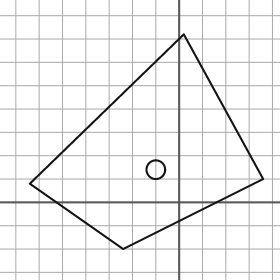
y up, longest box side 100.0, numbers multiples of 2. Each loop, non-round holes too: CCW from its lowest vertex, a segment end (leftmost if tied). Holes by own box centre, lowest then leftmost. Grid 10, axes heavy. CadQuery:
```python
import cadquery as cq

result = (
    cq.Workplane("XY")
    .moveTo(-24.0, -20.0)
    .lineTo(36.0, 10.0)
    .lineTo(2.0, 72.0)
    .lineTo(-64.0, 8.0)
    .close()
    .moveTo(-10.0, 14.0)
    .circle(4.0)
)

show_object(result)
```